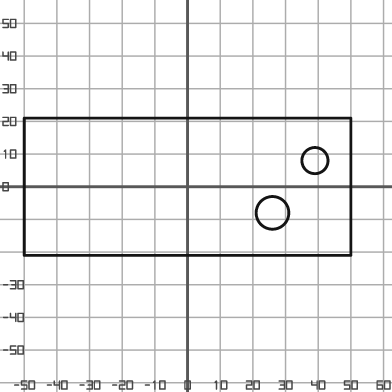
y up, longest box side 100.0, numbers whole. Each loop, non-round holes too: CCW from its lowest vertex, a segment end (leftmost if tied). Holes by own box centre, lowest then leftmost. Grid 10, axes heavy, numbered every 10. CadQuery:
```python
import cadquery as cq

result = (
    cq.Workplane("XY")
    .moveTo(-50.0, -21.0)
    .lineTo(50.0, -21.0)
    .lineTo(50.0, 21.0)
    .lineTo(-50.0, 21.0)
    .close()
    .moveTo(26.0, -8.0)
    .circle(5.0)
    .moveTo(39.0, 8.0)
    .circle(4.0)
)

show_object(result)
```